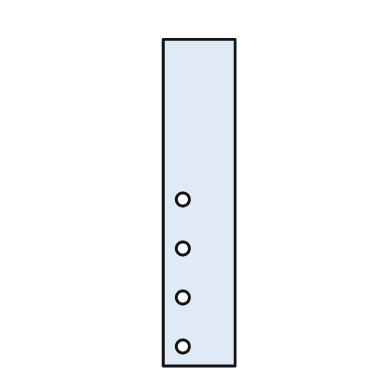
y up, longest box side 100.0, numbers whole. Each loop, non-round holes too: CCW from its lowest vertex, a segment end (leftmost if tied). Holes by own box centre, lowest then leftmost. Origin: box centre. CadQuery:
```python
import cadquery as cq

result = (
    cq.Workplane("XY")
    .moveTo(-11.0, -50.0)
    .lineTo(11.0, -50.0)
    .lineTo(11.0, 50.0)
    .lineTo(-11.0, 50.0)
    .close()
    .moveTo(-5.0, -44.0)
    .circle(2.0)
    .moveTo(-5.0, -29.0)
    .circle(2.0)
    .moveTo(-5.0, -14.0)
    .circle(2.0)
    .moveTo(-5.0, 1.0)
    .circle(2.0)
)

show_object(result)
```